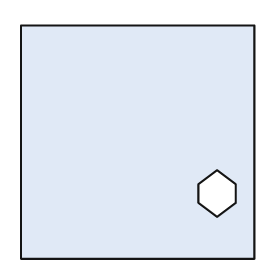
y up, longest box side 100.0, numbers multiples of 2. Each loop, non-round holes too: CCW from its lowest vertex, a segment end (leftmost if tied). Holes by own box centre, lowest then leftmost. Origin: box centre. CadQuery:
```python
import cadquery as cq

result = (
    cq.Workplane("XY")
    .moveTo(-50.0, -50.0)
    .lineTo(50.0, -50.0)
    .lineTo(50.0, 50.0)
    .lineTo(-50.0, 50.0)
    .close()
    .moveTo(34.0, -32.0)
    .lineTo(42.0, -26.0)
    .lineTo(42.0, -18.0)
    .lineTo(34.0, -12.0)
    .lineTo(26.0, -18.0)
    .lineTo(26.0, -26.0)
    .close()
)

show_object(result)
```